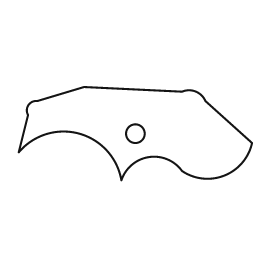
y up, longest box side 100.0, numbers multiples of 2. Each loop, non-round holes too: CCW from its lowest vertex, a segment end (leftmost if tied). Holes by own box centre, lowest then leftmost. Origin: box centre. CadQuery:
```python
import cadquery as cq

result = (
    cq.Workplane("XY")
    .moveTo(-6.0, -20.0)
    .threePointArc((6.0, -10.0), (20.0, -16.0))
    .threePointArc((38.0, -18.0), (50.0, -4.0))
    .lineTo(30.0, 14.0)
    .threePointArc((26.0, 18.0), (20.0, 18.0))
    .lineTo(-22.0, 20.0)
    .lineTo(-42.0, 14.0)
    .threePointArc((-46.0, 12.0), (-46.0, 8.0))
    .lineTo(-50.0, -8.0)
    .threePointArc((-24.0, 0.0), (-6.0, -20.0))
    .close()
    .moveTo(0.0, 0.0)
    .circle(4.0)
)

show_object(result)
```